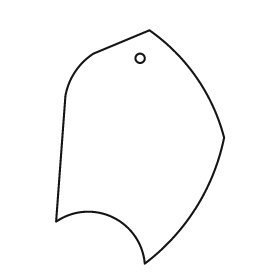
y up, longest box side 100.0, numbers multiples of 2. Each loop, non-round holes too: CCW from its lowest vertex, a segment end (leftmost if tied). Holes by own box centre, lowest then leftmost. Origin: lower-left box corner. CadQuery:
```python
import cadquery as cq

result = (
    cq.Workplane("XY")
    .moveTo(38.0, 0.0)
    .threePointArc((60.0, 24.0), (72.0, 54.0))
    .threePointArc((60.0, 80.0), (40.0, 100.0))
    .lineTo(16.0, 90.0)
    .threePointArc((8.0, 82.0), (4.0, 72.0))
    .lineTo(0.0, 18.0)
    .threePointArc((24.0, 20.0), (38.0, 0.0))
    .close()
    .moveTo(36.0, 88.0)
    .circle(2.0)
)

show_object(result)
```